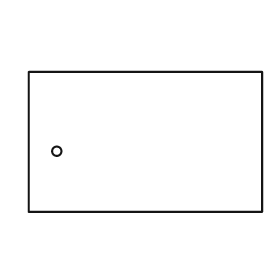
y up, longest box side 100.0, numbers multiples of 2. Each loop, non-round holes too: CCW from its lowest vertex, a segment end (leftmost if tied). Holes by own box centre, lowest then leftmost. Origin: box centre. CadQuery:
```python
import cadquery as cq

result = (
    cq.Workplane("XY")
    .moveTo(-50.0, -30.0)
    .lineTo(50.0, -30.0)
    .lineTo(50.0, 30.0)
    .lineTo(-50.0, 30.0)
    .close()
    .moveTo(-38.0, -4.0)
    .circle(2.0)
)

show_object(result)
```